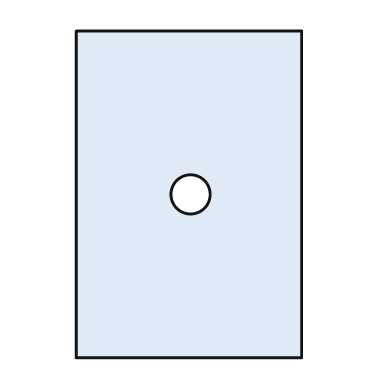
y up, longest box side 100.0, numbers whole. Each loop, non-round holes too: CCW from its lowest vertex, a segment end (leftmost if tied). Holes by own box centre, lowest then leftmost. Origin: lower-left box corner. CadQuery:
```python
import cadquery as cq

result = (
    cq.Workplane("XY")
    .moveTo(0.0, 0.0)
    .lineTo(69.0, 0.0)
    .lineTo(69.0, 100.0)
    .lineTo(0.0, 100.0)
    .close()
    .moveTo(35.0, 50.0)
    .circle(6.0)
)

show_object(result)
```